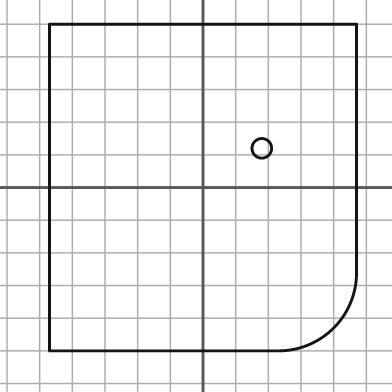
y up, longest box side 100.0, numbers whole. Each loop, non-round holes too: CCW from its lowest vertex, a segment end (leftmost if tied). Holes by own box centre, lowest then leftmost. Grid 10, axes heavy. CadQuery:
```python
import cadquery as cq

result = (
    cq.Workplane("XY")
    .moveTo(-47.0, -50.0)
    .lineTo(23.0, -50.0)
    .threePointArc((40.0, -43.0), (47.0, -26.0))
    .lineTo(47.0, 50.0)
    .lineTo(-47.0, 50.0)
    .close()
    .moveTo(18.0, 12.0)
    .circle(3.0)
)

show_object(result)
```